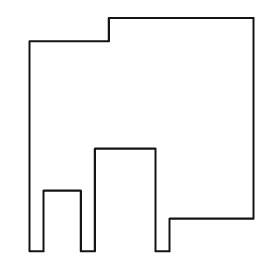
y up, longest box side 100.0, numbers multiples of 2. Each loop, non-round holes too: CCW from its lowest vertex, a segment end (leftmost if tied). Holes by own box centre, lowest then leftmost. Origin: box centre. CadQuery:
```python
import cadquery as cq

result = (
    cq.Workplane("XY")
    .moveTo(-48.0, -50.0)
    .lineTo(-42.0, -50.0)
    .lineTo(-42.0, -24.0)
    .lineTo(-26.0, -24.0)
    .lineTo(-26.0, -50.0)
    .lineTo(-20.0, -50.0)
    .lineTo(-20.0, -6.0)
    .lineTo(6.0, -6.0)
    .lineTo(6.0, -50.0)
    .lineTo(12.0, -50.0)
    .lineTo(12.0, -36.0)
    .lineTo(48.0, -36.0)
    .lineTo(48.0, 50.0)
    .lineTo(-14.0, 50.0)
    .lineTo(-14.0, 40.0)
    .lineTo(-48.0, 40.0)
    .close()
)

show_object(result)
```